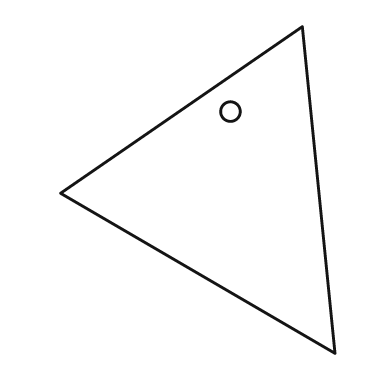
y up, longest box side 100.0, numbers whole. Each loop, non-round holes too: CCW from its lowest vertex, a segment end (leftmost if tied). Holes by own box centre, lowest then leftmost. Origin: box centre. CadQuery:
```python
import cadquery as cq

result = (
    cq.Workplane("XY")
    .moveTo(42.0, -50.0)
    .lineTo(32.0, 50.0)
    .lineTo(-42.0, -1.0)
    .close()
    .moveTo(10.0, 24.0)
    .circle(3.0)
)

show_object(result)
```